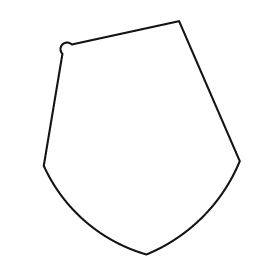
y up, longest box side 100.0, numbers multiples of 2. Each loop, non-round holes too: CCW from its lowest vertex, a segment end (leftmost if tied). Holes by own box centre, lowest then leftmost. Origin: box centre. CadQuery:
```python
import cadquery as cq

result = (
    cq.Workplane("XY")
    .moveTo(2.0, -50.0)
    .threePointArc((26.0, -34.0), (42.0, -10.0))
    .lineTo(16.0, 50.0)
    .lineTo(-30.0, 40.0)
    .threePointArc((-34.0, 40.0), (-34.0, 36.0))
    .lineTo(-42.0, -12.0)
    .threePointArc((-24.0, -36.0), (2.0, -50.0))
    .close()
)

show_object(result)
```